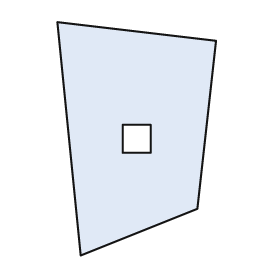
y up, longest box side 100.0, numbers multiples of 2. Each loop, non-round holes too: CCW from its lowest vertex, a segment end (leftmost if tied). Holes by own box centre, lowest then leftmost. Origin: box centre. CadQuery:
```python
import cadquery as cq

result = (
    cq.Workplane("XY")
    .moveTo(-24.0, -50.0)
    .lineTo(26.0, -30.0)
    .lineTo(34.0, 42.0)
    .lineTo(-34.0, 50.0)
    .close()
    .moveTo(-6.0, -6.0)
    .lineTo(6.0, -6.0)
    .lineTo(6.0, 6.0)
    .lineTo(-6.0, 6.0)
    .close()
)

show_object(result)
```